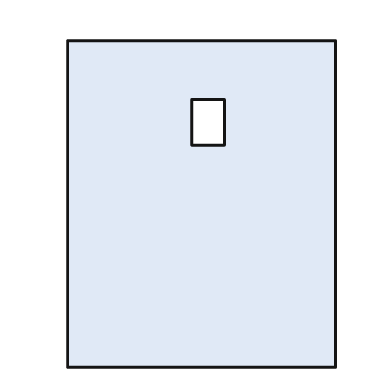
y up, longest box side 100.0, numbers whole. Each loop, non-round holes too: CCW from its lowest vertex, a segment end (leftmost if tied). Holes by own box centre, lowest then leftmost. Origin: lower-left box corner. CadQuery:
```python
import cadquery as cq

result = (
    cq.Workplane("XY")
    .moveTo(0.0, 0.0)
    .lineTo(82.0, 0.0)
    .lineTo(82.0, 100.0)
    .lineTo(0.0, 100.0)
    .close()
    .moveTo(38.0, 68.0)
    .lineTo(48.0, 68.0)
    .lineTo(48.0, 82.0)
    .lineTo(38.0, 82.0)
    .close()
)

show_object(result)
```